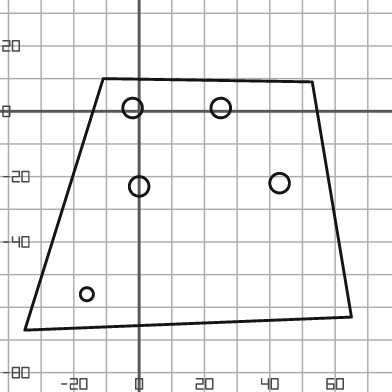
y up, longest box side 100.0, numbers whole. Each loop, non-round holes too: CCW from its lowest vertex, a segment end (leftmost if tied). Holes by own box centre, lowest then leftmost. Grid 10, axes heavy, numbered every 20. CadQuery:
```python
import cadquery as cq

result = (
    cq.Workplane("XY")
    .moveTo(-35.0, -67.0)
    .lineTo(65.0, -63.0)
    .lineTo(53.0, 9.0)
    .lineTo(-11.0, 10.0)
    .close()
    .moveTo(-16.0, -56.0)
    .circle(2.0)
    .moveTo(0.0, -23.0)
    .circle(3.0)
    .moveTo(43.0, -22.0)
    .circle(3.0)
    .moveTo(-2.0, 1.0)
    .circle(3.0)
    .moveTo(25.0, 1.0)
    .circle(3.0)
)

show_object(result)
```